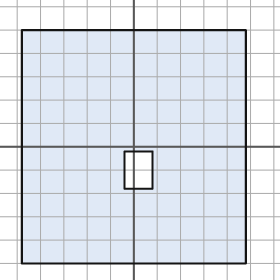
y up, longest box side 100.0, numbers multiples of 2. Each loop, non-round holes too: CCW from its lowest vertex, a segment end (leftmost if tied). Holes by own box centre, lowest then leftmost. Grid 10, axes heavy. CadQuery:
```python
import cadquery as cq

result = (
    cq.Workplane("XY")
    .moveTo(-48.0, -50.0)
    .lineTo(48.0, -50.0)
    .lineTo(48.0, 50.0)
    .lineTo(-48.0, 50.0)
    .close()
    .moveTo(-4.0, -18.0)
    .lineTo(8.0, -18.0)
    .lineTo(8.0, -2.0)
    .lineTo(-4.0, -2.0)
    .close()
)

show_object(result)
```